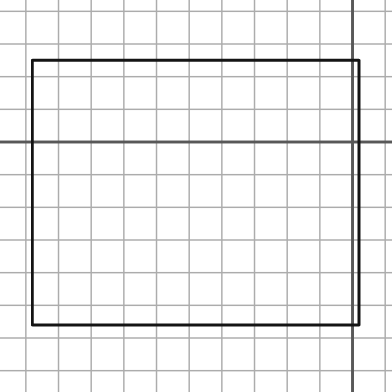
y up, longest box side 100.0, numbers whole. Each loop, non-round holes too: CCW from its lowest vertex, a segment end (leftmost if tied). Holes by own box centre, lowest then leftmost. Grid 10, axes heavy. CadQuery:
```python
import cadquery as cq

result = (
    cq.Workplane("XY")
    .moveTo(-98.0, -56.0)
    .lineTo(2.0, -56.0)
    .lineTo(2.0, 25.0)
    .lineTo(-98.0, 25.0)
    .close()
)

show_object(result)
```